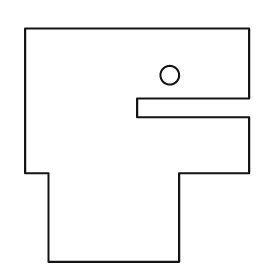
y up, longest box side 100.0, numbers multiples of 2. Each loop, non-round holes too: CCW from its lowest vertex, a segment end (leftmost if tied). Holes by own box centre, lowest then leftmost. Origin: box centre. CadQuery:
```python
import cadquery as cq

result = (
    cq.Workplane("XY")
    .moveTo(-38.0, -50.0)
    .lineTo(18.0, -50.0)
    .lineTo(18.0, -12.0)
    .lineTo(48.0, -12.0)
    .lineTo(48.0, 12.0)
    .lineTo(0.0, 12.0)
    .lineTo(0.0, 20.0)
    .lineTo(48.0, 20.0)
    .lineTo(48.0, 50.0)
    .lineTo(-48.0, 50.0)
    .lineTo(-48.0, -12.0)
    .lineTo(-38.0, -12.0)
    .close()
    .moveTo(14.0, 30.0)
    .circle(4.0)
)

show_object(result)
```